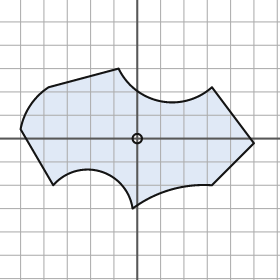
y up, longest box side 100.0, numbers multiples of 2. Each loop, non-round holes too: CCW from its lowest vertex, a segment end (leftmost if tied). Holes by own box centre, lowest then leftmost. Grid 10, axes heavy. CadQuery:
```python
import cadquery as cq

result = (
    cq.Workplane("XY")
    .moveTo(-2.0, -30.0)
    .threePointArc((14.0, -22.0), (32.0, -20.0))
    .lineTo(50.0, -2.0)
    .lineTo(32.0, 22.0)
    .threePointArc((10.0, 16.0), (-8.0, 30.0))
    .lineTo(-38.0, 22.0)
    .threePointArc((-46.0, 14.0), (-50.0, 4.0))
    .lineTo(-36.0, -20.0)
    .threePointArc((-16.0, -14.0), (-2.0, -30.0))
    .close()
    .moveTo(0.0, 0.0)
    .circle(2.0)
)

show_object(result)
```